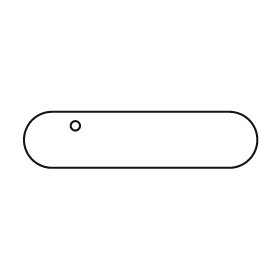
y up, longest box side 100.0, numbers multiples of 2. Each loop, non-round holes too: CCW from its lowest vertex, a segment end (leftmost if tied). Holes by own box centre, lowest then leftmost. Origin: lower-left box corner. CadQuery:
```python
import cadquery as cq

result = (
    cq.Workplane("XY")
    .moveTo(12.0, 0.0)
    .lineTo(88.0, 0.0)
    .threePointArc((100.0, 12.0), (88.0, 24.0))
    .lineTo(12.0, 24.0)
    .threePointArc((0.0, 12.0), (12.0, 0.0))
    .close()
    .moveTo(22.0, 18.0)
    .circle(2.0)
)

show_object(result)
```